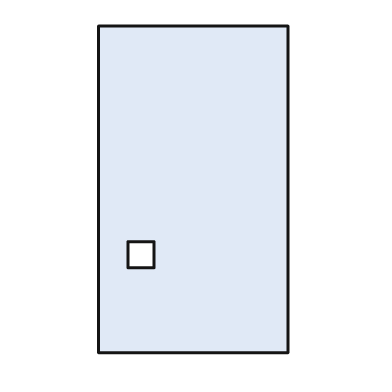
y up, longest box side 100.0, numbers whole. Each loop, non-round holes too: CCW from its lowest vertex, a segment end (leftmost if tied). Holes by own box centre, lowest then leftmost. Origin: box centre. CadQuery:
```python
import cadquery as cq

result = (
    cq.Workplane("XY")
    .moveTo(-29.0, -50.0)
    .lineTo(29.0, -50.0)
    .lineTo(29.0, 50.0)
    .lineTo(-29.0, 50.0)
    .close()
    .moveTo(-20.0, -24.0)
    .lineTo(-12.0, -24.0)
    .lineTo(-12.0, -16.0)
    .lineTo(-20.0, -16.0)
    .close()
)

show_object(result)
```